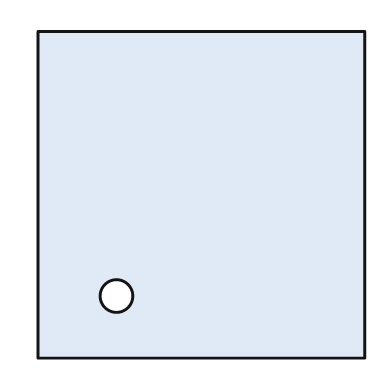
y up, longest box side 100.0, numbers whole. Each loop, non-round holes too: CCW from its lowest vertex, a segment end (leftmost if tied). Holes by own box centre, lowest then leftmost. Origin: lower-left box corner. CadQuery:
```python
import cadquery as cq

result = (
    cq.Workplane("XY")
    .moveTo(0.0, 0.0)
    .lineTo(100.0, 0.0)
    .lineTo(100.0, 100.0)
    .lineTo(0.0, 100.0)
    .close()
    .moveTo(24.0, 19.0)
    .circle(5.0)
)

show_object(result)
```